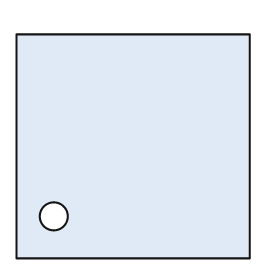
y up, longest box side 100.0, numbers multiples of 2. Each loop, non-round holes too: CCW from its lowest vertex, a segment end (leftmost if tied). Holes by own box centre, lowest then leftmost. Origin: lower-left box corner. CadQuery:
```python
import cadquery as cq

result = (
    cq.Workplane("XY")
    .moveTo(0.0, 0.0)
    .lineTo(100.0, 0.0)
    .lineTo(100.0, 96.0)
    .lineTo(0.0, 96.0)
    .close()
    .moveTo(16.0, 18.0)
    .circle(6.0)
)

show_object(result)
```